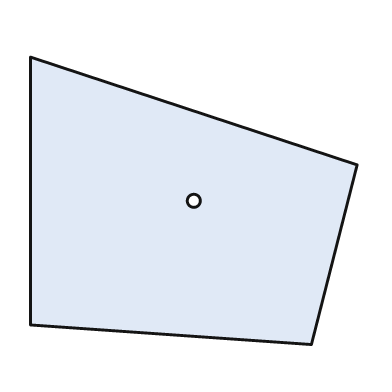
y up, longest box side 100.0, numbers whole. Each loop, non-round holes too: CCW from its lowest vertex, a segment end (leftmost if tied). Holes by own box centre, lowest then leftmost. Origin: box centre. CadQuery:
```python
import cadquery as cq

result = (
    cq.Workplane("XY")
    .moveTo(36.0, -44.0)
    .lineTo(50.0, 11.0)
    .lineTo(-50.0, 44.0)
    .lineTo(-50.0, -38.0)
    .close()
    .moveTo(0.0, 0.0)
    .circle(2.0)
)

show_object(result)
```